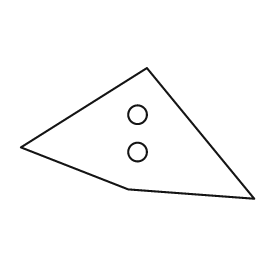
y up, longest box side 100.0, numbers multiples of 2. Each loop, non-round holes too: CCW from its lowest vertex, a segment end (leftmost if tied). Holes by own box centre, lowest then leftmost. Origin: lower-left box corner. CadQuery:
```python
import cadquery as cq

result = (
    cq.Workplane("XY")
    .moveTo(100.0, 0.0)
    .lineTo(54.0, 56.0)
    .lineTo(0.0, 22.0)
    .lineTo(46.0, 4.0)
    .close()
    .moveTo(50.0, 20.0)
    .circle(4.0)
    .moveTo(50.0, 36.0)
    .circle(4.0)
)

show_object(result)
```